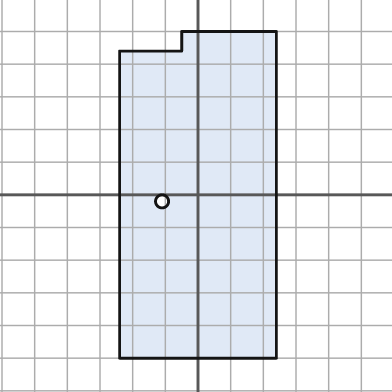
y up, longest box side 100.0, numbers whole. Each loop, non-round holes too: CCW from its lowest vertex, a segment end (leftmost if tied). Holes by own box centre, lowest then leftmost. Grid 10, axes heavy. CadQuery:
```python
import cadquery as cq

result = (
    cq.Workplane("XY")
    .moveTo(-24.0, -50.0)
    .lineTo(24.0, -50.0)
    .lineTo(24.0, 50.0)
    .lineTo(-5.0, 50.0)
    .lineTo(-5.0, 44.0)
    .lineTo(-24.0, 44.0)
    .close()
    .moveTo(-11.0, -2.0)
    .circle(2.0)
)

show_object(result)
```